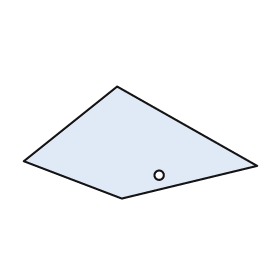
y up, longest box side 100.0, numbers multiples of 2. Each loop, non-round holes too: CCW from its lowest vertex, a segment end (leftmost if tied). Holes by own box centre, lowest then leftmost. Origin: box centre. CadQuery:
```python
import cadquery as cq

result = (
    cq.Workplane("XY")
    .moveTo(-8.0, -24.0)
    .lineTo(50.0, -10.0)
    .lineTo(-10.0, 24.0)
    .lineTo(-50.0, -8.0)
    .close()
    .moveTo(8.0, -14.0)
    .circle(2.0)
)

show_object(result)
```